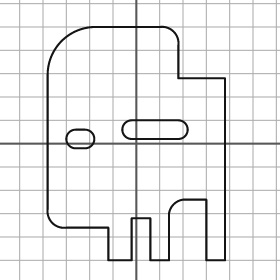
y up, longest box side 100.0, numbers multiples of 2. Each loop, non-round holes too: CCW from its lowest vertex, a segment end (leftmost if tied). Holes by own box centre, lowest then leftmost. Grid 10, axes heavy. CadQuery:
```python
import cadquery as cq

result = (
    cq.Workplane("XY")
    .moveTo(-12.0, -50.0)
    .lineTo(-2.0, -50.0)
    .lineTo(-2.0, -32.0)
    .lineTo(6.0, -32.0)
    .lineTo(6.0, -50.0)
    .lineTo(14.0, -50.0)
    .lineTo(14.0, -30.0)
    .threePointArc((16.0, -26.0), (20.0, -24.0))
    .lineTo(30.0, -24.0)
    .lineTo(30.0, -50.0)
    .lineTo(38.0, -50.0)
    .lineTo(38.0, 28.0)
    .lineTo(18.0, 28.0)
    .lineTo(18.0, 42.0)
    .threePointArc((16.0, 48.0), (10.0, 50.0))
    .lineTo(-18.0, 50.0)
    .threePointArc((-32.0, 44.0), (-38.0, 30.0))
    .lineTo(-38.0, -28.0)
    .threePointArc((-36.0, -34.0), (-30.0, -36.0))
    .lineTo(-12.0, -36.0)
    .close()
    .moveTo(-26.0, -2.0)
    .lineTo(-22.0, -2.0)
    .threePointArc((-18.0, 2.0), (-22.0, 6.0))
    .lineTo(-26.0, 6.0)
    .threePointArc((-30.0, 2.0), (-26.0, -2.0))
    .close()
    .moveTo(-2.0, 2.0)
    .lineTo(18.0, 2.0)
    .threePointArc((22.0, 6.0), (18.0, 10.0))
    .lineTo(-2.0, 10.0)
    .threePointArc((-6.0, 6.0), (-2.0, 2.0))
    .close()
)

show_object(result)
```